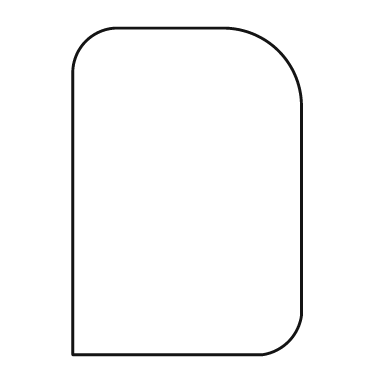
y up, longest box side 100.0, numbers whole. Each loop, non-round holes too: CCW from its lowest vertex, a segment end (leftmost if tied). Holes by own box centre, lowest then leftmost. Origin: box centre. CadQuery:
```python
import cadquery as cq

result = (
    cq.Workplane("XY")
    .moveTo(-35.0, -50.0)
    .lineTo(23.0, -50.0)
    .threePointArc((31.0, -46.0), (35.0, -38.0))
    .lineTo(35.0, 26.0)
    .threePointArc((28.0, 43.0), (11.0, 50.0))
    .lineTo(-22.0, 50.0)
    .threePointArc((-31.0, 46.0), (-35.0, 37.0))
    .close()
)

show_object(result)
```